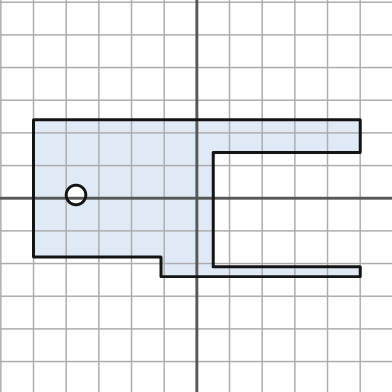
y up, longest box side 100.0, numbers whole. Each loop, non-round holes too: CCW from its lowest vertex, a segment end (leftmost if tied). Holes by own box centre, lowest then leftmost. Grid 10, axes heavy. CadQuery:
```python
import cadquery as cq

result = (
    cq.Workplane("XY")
    .moveTo(-11.0, -24.0)
    .lineTo(50.0, -24.0)
    .lineTo(50.0, -21.0)
    .lineTo(5.0, -21.0)
    .lineTo(5.0, 14.0)
    .lineTo(50.0, 14.0)
    .lineTo(50.0, 24.0)
    .lineTo(-50.0, 24.0)
    .lineTo(-50.0, -18.0)
    .lineTo(-11.0, -18.0)
    .close()
    .moveTo(-37.0, 1.0)
    .circle(3.0)
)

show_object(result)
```